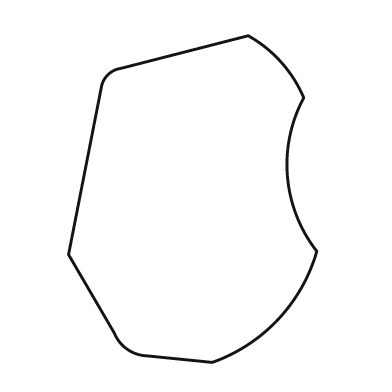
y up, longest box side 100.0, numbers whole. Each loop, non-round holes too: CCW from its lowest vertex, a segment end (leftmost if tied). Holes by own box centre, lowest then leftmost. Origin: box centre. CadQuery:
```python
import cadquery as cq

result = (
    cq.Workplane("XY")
    .moveTo(6.0, -50.0)
    .threePointArc((26.0, -37.0), (38.0, -16.0))
    .threePointArc((29.0, 7.0), (34.0, 31.0))
    .threePointArc((27.0, 42.0), (17.0, 50.0))
    .lineTo(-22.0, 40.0)
    .threePointArc((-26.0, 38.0), (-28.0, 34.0))
    .lineTo(-38.0, -17.0)
    .lineTo(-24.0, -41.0)
    .threePointArc((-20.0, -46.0), (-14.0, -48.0))
    .close()
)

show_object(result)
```